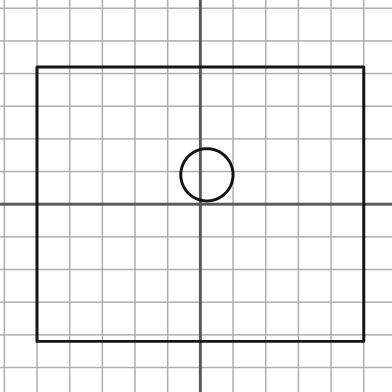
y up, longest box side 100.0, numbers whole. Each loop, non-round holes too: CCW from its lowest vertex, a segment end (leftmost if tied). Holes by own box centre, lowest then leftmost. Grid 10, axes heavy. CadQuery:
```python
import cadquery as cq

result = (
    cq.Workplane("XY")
    .moveTo(-50.0, -42.0)
    .lineTo(50.0, -42.0)
    .lineTo(50.0, 42.0)
    .lineTo(-50.0, 42.0)
    .close()
    .moveTo(2.0, 9.0)
    .circle(8.0)
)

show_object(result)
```